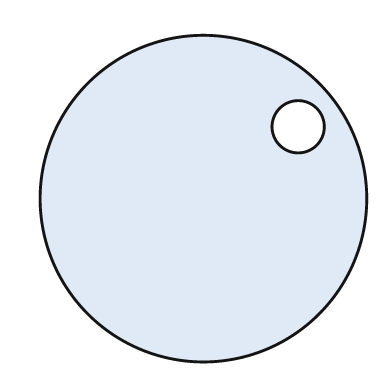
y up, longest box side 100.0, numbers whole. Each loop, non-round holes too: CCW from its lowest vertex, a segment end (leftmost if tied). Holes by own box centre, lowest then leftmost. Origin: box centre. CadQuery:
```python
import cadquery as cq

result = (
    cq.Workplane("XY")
    .moveTo(0.0, 0.0)
    .circle(50.0)
    .moveTo(29.0, 22.0)
    .circle(8.0)
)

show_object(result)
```